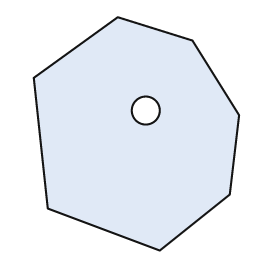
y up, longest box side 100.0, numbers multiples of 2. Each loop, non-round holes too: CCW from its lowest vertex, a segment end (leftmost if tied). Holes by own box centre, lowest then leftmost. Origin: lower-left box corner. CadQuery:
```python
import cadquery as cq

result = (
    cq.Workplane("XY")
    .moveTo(54.0, 0.0)
    .lineTo(84.0, 24.0)
    .lineTo(88.0, 58.0)
    .lineTo(68.0, 90.0)
    .lineTo(36.0, 100.0)
    .lineTo(0.0, 74.0)
    .lineTo(6.0, 18.0)
    .close()
    .moveTo(48.0, 60.0)
    .circle(6.0)
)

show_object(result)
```